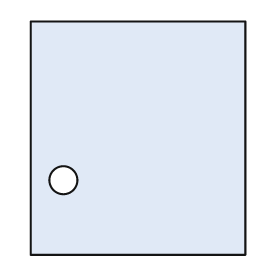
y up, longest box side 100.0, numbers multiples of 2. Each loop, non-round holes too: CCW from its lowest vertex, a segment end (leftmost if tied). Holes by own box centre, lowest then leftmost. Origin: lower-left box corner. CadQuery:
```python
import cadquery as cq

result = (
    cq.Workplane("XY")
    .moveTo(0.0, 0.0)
    .lineTo(92.0, 0.0)
    .lineTo(92.0, 100.0)
    .lineTo(0.0, 100.0)
    .close()
    .moveTo(14.0, 32.0)
    .circle(6.0)
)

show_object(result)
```